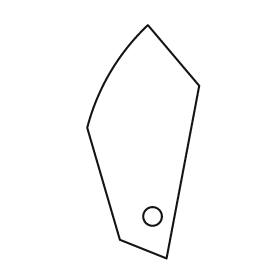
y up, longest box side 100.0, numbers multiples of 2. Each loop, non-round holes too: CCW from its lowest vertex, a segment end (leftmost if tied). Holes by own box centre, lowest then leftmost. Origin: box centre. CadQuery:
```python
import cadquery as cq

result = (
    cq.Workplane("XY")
    .moveTo(10.0, -50.0)
    .lineTo(24.0, 24.0)
    .lineTo(2.0, 50.0)
    .threePointArc((-14.0, 30.0), (-24.0, 6.0))
    .lineTo(-10.0, -42.0)
    .close()
    .moveTo(4.0, -32.0)
    .circle(4.0)
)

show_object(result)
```